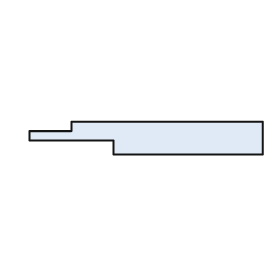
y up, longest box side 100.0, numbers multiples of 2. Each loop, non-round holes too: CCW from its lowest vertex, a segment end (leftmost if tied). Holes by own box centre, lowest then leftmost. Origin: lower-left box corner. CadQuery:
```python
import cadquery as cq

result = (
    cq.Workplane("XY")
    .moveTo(36.0, 0.0)
    .lineTo(100.0, 0.0)
    .lineTo(100.0, 14.0)
    .lineTo(18.0, 14.0)
    .lineTo(18.0, 10.0)
    .lineTo(0.0, 10.0)
    .lineTo(0.0, 6.0)
    .lineTo(36.0, 6.0)
    .close()
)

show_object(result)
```